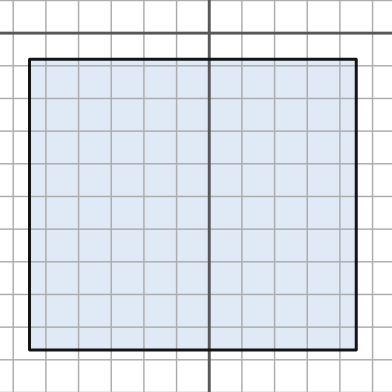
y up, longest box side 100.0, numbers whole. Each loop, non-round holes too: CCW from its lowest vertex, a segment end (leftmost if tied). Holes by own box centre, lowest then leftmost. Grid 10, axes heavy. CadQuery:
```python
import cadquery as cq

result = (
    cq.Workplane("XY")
    .moveTo(-55.0, -97.0)
    .lineTo(45.0, -97.0)
    .lineTo(45.0, -8.0)
    .lineTo(-55.0, -8.0)
    .close()
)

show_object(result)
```